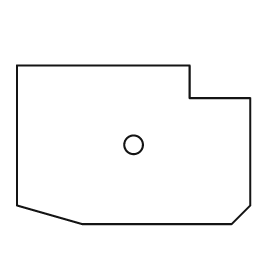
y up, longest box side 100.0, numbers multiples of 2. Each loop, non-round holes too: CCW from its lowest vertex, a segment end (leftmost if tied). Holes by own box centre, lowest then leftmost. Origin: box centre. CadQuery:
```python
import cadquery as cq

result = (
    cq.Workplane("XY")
    .moveTo(-22.0, -34.0)
    .lineTo(42.0, -34.0)
    .lineTo(50.0, -26.0)
    .lineTo(50.0, 20.0)
    .lineTo(24.0, 20.0)
    .lineTo(24.0, 34.0)
    .lineTo(-50.0, 34.0)
    .lineTo(-50.0, -26.0)
    .close()
    .moveTo(0.0, 0.0)
    .circle(4.0)
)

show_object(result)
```